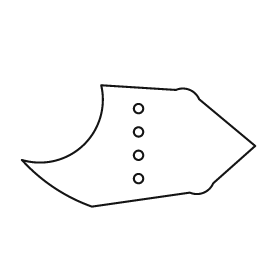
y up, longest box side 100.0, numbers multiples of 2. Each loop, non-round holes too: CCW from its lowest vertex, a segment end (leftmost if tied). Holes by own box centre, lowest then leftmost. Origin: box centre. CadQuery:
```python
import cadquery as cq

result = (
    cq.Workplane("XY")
    .moveTo(-20.0, -26.0)
    .lineTo(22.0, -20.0)
    .threePointArc((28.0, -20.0), (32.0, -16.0))
    .lineTo(50.0, 0.0)
    .lineTo(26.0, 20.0)
    .threePointArc((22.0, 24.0), (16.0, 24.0))
    .lineTo(-16.0, 26.0)
    .threePointArc((-24.0, 0.0), (-50.0, -6.0))
    .threePointArc((-36.0, -18.0), (-20.0, -26.0))
    .close()
    .moveTo(0.0, -14.0)
    .circle(2.0)
    .moveTo(0.0, -4.0)
    .circle(2.0)
    .moveTo(0.0, 6.0)
    .circle(2.0)
    .moveTo(0.0, 16.0)
    .circle(2.0)
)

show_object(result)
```